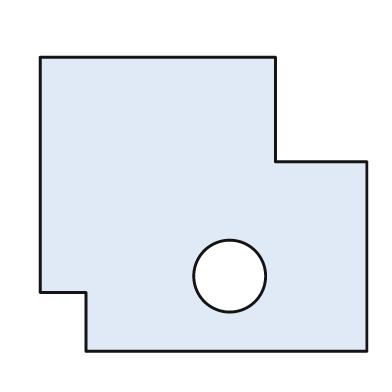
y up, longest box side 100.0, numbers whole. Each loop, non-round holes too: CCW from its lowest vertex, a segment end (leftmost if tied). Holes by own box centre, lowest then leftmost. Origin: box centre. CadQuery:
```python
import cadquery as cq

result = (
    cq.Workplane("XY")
    .moveTo(-36.0, -45.0)
    .lineTo(50.0, -45.0)
    .lineTo(50.0, 13.0)
    .lineTo(22.0, 13.0)
    .lineTo(22.0, 45.0)
    .lineTo(-50.0, 45.0)
    .lineTo(-50.0, -27.0)
    .lineTo(-36.0, -27.0)
    .close()
    .moveTo(8.0, -22.0)
    .circle(11.0)
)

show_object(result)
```